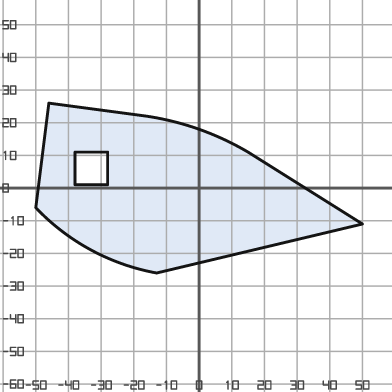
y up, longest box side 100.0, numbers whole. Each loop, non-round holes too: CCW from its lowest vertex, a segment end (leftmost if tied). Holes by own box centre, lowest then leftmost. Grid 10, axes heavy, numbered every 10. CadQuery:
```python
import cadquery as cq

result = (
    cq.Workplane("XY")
    .moveTo(-13.0, -26.0)
    .lineTo(50.0, -11.0)
    .lineTo(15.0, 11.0)
    .threePointArc((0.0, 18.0), (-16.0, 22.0))
    .lineTo(-46.0, 26.0)
    .lineTo(-50.0, -6.0)
    .threePointArc((-33.0, -19.0), (-13.0, -26.0))
    .close()
    .moveTo(-38.0, 1.0)
    .lineTo(-28.0, 1.0)
    .lineTo(-28.0, 11.0)
    .lineTo(-38.0, 11.0)
    .close()
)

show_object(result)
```